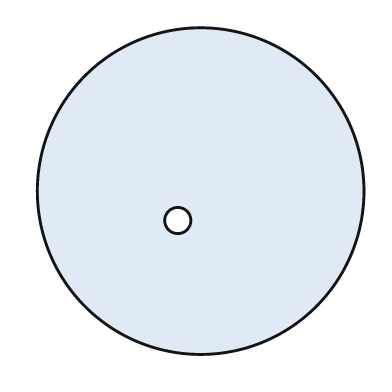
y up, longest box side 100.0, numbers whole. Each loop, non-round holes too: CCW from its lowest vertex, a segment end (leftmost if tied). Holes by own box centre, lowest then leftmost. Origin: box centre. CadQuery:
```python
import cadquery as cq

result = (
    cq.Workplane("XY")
    .moveTo(0.0, 0.0)
    .circle(50.0)
    .moveTo(-7.0, -9.0)
    .circle(4.0)
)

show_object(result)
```